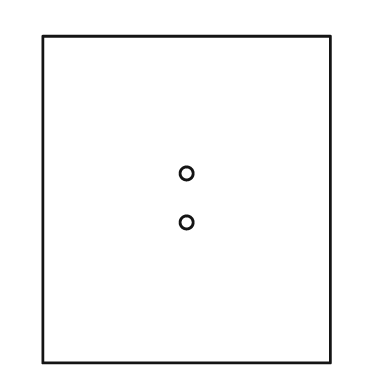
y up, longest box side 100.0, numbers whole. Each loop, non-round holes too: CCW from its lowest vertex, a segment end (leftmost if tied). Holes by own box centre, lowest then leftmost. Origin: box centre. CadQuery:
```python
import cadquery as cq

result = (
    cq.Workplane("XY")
    .moveTo(-44.0, -50.0)
    .lineTo(44.0, -50.0)
    .lineTo(44.0, 50.0)
    .lineTo(-44.0, 50.0)
    .close()
    .moveTo(0.0, -7.0)
    .circle(2.0)
    .moveTo(0.0, 8.0)
    .circle(2.0)
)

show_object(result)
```